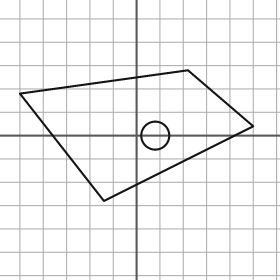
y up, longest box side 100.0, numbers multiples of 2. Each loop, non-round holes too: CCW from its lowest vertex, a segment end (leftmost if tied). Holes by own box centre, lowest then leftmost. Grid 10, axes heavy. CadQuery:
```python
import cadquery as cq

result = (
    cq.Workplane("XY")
    .moveTo(-14.0, -28.0)
    .lineTo(50.0, 4.0)
    .lineTo(22.0, 28.0)
    .lineTo(-50.0, 18.0)
    .close()
    .moveTo(8.0, 0.0)
    .circle(6.0)
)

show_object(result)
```